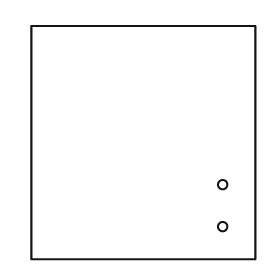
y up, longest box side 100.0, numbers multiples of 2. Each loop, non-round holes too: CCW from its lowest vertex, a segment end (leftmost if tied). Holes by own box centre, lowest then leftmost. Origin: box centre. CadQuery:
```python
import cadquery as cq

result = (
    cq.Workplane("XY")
    .moveTo(-48.0, -50.0)
    .lineTo(48.0, -50.0)
    .lineTo(48.0, 50.0)
    .lineTo(-48.0, 50.0)
    .close()
    .moveTo(34.0, -36.0)
    .circle(2.0)
    .moveTo(34.0, -18.0)
    .circle(2.0)
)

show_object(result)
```